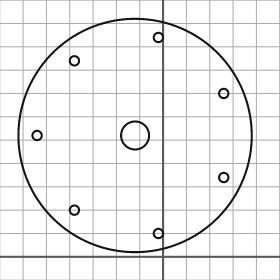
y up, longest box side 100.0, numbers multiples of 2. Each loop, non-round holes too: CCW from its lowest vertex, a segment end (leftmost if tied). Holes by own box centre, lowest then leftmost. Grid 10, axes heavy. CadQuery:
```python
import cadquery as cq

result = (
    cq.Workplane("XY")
    .moveTo(-12.0, 52.0)
    .circle(50.0)
    .moveTo(-2.0, 10.0)
    .circle(2.0)
    .moveTo(-38.0, 20.0)
    .circle(2.0)
    .moveTo(26.0, 34.0)
    .circle(2.0)
    .moveTo(-54.0, 52.0)
    .circle(2.0)
    .moveTo(-12.0, 52.0)
    .circle(6.0)
    .moveTo(26.0, 70.0)
    .circle(2.0)
    .moveTo(-38.0, 84.0)
    .circle(2.0)
    .moveTo(-2.0, 94.0)
    .circle(2.0)
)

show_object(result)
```